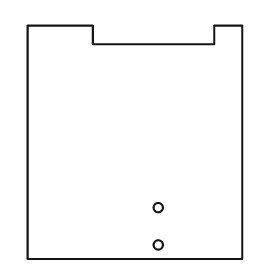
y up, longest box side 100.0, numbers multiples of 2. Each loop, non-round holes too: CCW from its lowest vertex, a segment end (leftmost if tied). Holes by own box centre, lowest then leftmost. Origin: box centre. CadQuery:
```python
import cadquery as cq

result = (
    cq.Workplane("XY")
    .moveTo(-46.0, -50.0)
    .lineTo(46.0, -50.0)
    .lineTo(46.0, 50.0)
    .lineTo(34.0, 50.0)
    .lineTo(34.0, 42.0)
    .lineTo(-18.0, 42.0)
    .lineTo(-18.0, 50.0)
    .lineTo(-46.0, 50.0)
    .close()
    .moveTo(10.0, -44.0)
    .circle(2.0)
    .moveTo(10.0, -28.0)
    .circle(2.0)
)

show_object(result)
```